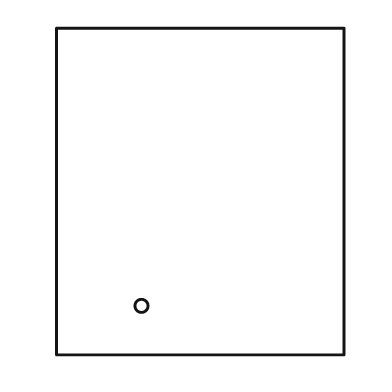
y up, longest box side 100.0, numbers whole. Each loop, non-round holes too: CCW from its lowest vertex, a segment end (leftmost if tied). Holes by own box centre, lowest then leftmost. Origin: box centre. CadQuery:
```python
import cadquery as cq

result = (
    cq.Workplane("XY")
    .moveTo(-44.0, -50.0)
    .lineTo(44.0, -50.0)
    .lineTo(44.0, 50.0)
    .lineTo(-44.0, 50.0)
    .close()
    .moveTo(-18.0, -35.0)
    .circle(2.0)
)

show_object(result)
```